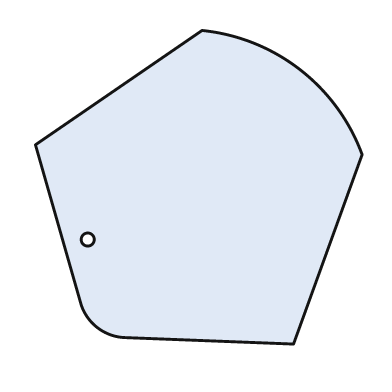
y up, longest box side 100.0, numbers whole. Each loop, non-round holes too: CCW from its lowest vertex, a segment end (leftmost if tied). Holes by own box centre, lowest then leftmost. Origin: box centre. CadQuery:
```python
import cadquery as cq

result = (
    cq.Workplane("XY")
    .moveTo(29.0, -48.0)
    .lineTo(50.0, 10.0)
    .threePointArc((31.0, 36.0), (1.0, 48.0))
    .lineTo(-50.0, 13.0)
    .lineTo(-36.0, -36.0)
    .threePointArc((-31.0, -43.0), (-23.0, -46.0))
    .close()
    .moveTo(-34.0, -16.0)
    .circle(2.0)
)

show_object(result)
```